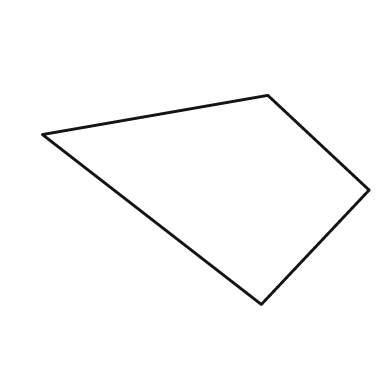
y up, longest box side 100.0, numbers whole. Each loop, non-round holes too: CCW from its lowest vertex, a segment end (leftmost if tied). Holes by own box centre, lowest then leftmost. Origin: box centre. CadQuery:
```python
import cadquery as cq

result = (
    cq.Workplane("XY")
    .moveTo(17.0, -32.0)
    .lineTo(50.0, 3.0)
    .lineTo(19.0, 32.0)
    .lineTo(-50.0, 20.0)
    .close()
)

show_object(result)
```